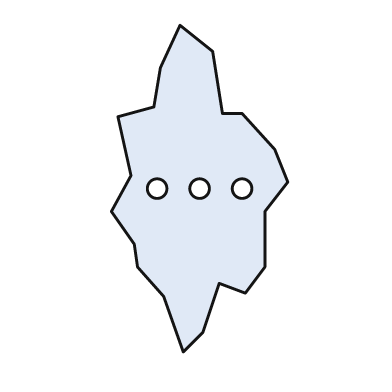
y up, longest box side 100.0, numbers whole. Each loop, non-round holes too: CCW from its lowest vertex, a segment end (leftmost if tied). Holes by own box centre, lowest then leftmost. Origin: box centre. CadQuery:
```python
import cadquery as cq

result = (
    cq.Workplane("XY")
    .moveTo(-5.0, -50.0)
    .lineTo(1.0, -44.0)
    .lineTo(6.0, -29.0)
    .lineTo(14.0, -32.0)
    .lineTo(20.0, -24.0)
    .lineTo(20.0, -7.0)
    .lineTo(27.0, 2.0)
    .lineTo(23.0, 12.0)
    .lineTo(13.0, 23.0)
    .lineTo(7.0, 23.0)
    .lineTo(4.0, 42.0)
    .lineTo(-6.0, 50.0)
    .lineTo(-12.0, 37.0)
    .lineTo(-14.0, 25.0)
    .lineTo(-25.0, 22.0)
    .lineTo(-21.0, 4.0)
    .lineTo(-27.0, -7.0)
    .lineTo(-20.0, -17.0)
    .lineTo(-19.0, -24.0)
    .lineTo(-11.0, -33.0)
    .close()
    .moveTo(-13.0, 0.0)
    .circle(3.0)
    .moveTo(0.0, 0.0)
    .circle(3.0)
    .moveTo(13.0, 0.0)
    .circle(3.0)
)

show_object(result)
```